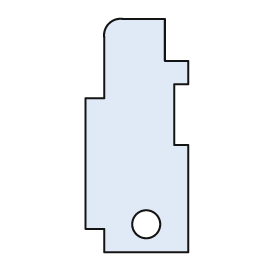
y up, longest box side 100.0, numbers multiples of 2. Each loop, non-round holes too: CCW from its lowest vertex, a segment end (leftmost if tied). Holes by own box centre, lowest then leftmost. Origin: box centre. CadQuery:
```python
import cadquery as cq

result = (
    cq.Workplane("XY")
    .moveTo(-14.0, -50.0)
    .lineTo(22.0, -50.0)
    .lineTo(22.0, -4.0)
    .lineTo(16.0, -4.0)
    .lineTo(16.0, 22.0)
    .lineTo(22.0, 22.0)
    .lineTo(22.0, 32.0)
    .lineTo(12.0, 32.0)
    .lineTo(12.0, 50.0)
    .lineTo(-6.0, 50.0)
    .threePointArc((-12.0, 48.0), (-14.0, 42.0))
    .lineTo(-14.0, 16.0)
    .lineTo(-22.0, 16.0)
    .lineTo(-22.0, -40.0)
    .lineTo(-14.0, -40.0)
    .close()
    .moveTo(4.0, -38.0)
    .circle(6.0)
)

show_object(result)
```